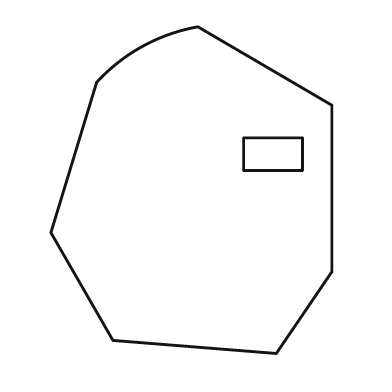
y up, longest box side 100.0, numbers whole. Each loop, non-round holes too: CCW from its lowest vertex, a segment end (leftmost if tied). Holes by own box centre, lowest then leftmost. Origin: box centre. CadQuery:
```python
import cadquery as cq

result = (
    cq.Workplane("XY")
    .moveTo(26.0, -50.0)
    .lineTo(43.0, -25.0)
    .lineTo(43.0, 26.0)
    .lineTo(2.0, 50.0)
    .threePointArc((-15.0, 44.0), (-29.0, 33.0))
    .lineTo(-43.0, -13.0)
    .lineTo(-24.0, -46.0)
    .close()
    .moveTo(16.0, 6.0)
    .lineTo(34.0, 6.0)
    .lineTo(34.0, 16.0)
    .lineTo(16.0, 16.0)
    .close()
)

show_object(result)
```